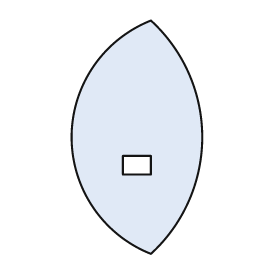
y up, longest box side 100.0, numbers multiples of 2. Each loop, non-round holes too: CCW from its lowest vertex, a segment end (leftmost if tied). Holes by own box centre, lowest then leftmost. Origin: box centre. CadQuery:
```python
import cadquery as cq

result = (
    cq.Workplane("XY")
    .moveTo(6.0, -50.0)
    .threePointArc((28.0, 0.0), (6.0, 50.0))
    .threePointArc((-28.0, 0.0), (6.0, -50.0))
    .close()
    .moveTo(-6.0, -16.0)
    .lineTo(6.0, -16.0)
    .lineTo(6.0, -8.0)
    .lineTo(-6.0, -8.0)
    .close()
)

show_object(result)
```